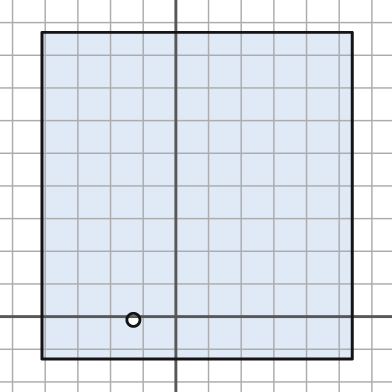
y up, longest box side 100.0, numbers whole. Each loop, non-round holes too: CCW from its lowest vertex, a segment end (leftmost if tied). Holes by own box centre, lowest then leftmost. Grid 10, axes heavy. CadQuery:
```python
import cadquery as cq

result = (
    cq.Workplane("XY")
    .moveTo(-41.0, -13.0)
    .lineTo(54.0, -13.0)
    .lineTo(54.0, 87.0)
    .lineTo(-41.0, 87.0)
    .close()
    .moveTo(-13.0, -1.0)
    .circle(2.0)
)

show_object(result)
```